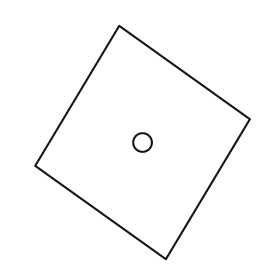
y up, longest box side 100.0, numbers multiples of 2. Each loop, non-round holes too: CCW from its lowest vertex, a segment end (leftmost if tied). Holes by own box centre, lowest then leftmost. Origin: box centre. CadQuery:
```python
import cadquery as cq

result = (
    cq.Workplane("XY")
    .moveTo(10.0, -50.0)
    .lineTo(46.0, 10.0)
    .lineTo(-10.0, 50.0)
    .lineTo(-46.0, -10.0)
    .close()
    .moveTo(0.0, 0.0)
    .circle(4.0)
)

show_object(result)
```